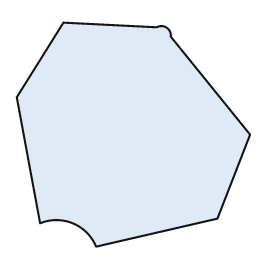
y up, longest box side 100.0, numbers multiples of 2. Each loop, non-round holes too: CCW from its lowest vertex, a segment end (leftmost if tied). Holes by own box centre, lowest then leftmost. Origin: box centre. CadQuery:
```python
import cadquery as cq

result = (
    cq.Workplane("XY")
    .moveTo(-16.0, -48.0)
    .lineTo(36.0, -36.0)
    .lineTo(50.0, 0.0)
    .lineTo(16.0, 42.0)
    .threePointArc((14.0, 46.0), (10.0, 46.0))
    .lineTo(-30.0, 48.0)
    .lineTo(-50.0, 16.0)
    .lineTo(-40.0, -38.0)
    .threePointArc((-26.0, -38.0), (-16.0, -48.0))
    .close()
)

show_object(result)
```